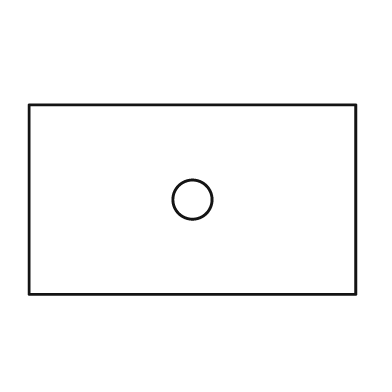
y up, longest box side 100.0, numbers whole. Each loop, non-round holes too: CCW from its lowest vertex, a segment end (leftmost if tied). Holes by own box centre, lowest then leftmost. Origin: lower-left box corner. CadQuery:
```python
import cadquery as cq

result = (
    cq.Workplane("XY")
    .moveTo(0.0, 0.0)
    .lineTo(100.0, 0.0)
    .lineTo(100.0, 58.0)
    .lineTo(0.0, 58.0)
    .close()
    .moveTo(50.0, 29.0)
    .circle(6.0)
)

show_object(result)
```